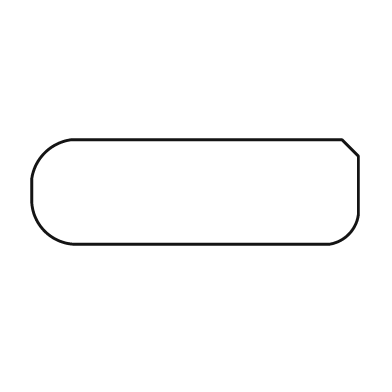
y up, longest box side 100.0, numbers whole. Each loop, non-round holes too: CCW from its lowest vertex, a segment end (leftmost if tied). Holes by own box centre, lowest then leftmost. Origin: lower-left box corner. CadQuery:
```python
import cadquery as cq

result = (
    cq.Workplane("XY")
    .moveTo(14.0, 0.0)
    .lineTo(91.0, 0.0)
    .threePointArc((97.0, 3.0), (100.0, 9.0))
    .lineTo(100.0, 27.0)
    .lineTo(95.0, 32.0)
    .lineTo(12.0, 32.0)
    .threePointArc((4.0, 28.0), (0.0, 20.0))
    .lineTo(0.0, 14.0)
    .threePointArc((4.0, 4.0), (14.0, 0.0))
    .close()
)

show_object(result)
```